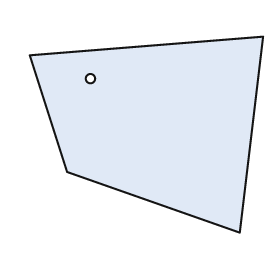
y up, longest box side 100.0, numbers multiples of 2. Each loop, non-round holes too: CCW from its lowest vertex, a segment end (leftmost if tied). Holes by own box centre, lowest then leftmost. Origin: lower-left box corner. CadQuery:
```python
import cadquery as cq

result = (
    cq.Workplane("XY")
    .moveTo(90.0, 0.0)
    .lineTo(100.0, 84.0)
    .lineTo(0.0, 76.0)
    .lineTo(16.0, 26.0)
    .close()
    .moveTo(26.0, 66.0)
    .circle(2.0)
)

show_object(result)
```